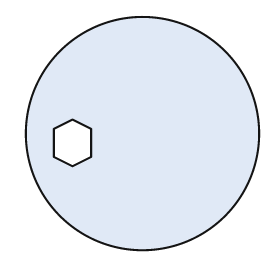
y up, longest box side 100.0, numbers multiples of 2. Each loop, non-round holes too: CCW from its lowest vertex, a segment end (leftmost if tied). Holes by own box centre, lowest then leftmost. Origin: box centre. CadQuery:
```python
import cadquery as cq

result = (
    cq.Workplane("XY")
    .moveTo(0.0, 0.0)
    .circle(50.0)
    .moveTo(-30.0, -14.0)
    .lineTo(-22.0, -10.0)
    .lineTo(-22.0, 2.0)
    .lineTo(-30.0, 6.0)
    .lineTo(-38.0, 2.0)
    .lineTo(-38.0, -10.0)
    .close()
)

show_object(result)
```